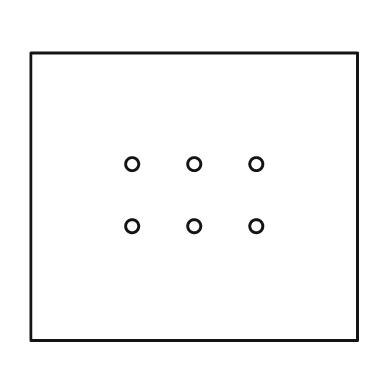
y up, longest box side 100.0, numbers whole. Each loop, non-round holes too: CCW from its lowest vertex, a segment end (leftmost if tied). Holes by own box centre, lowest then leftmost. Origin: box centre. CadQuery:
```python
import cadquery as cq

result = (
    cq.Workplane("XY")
    .moveTo(-50.0, -44.0)
    .lineTo(50.0, -44.0)
    .lineTo(50.0, 44.0)
    .lineTo(-50.0, 44.0)
    .close()
    .moveTo(-19.0, -9.0)
    .circle(2.0)
    .moveTo(0.0, -9.0)
    .circle(2.0)
    .moveTo(19.0, -9.0)
    .circle(2.0)
    .moveTo(-19.0, 10.0)
    .circle(2.0)
    .moveTo(0.0, 10.0)
    .circle(2.0)
    .moveTo(19.0, 10.0)
    .circle(2.0)
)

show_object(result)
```